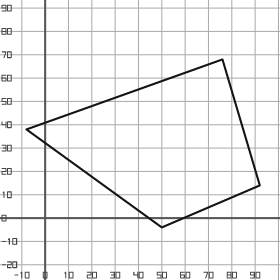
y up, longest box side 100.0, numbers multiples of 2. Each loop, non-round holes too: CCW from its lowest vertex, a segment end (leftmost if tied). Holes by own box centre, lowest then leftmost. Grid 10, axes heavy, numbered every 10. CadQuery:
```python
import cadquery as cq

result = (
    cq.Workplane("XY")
    .moveTo(50.0, -4.0)
    .lineTo(92.0, 14.0)
    .lineTo(76.0, 68.0)
    .lineTo(-8.0, 38.0)
    .close()
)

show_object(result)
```